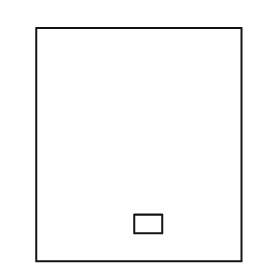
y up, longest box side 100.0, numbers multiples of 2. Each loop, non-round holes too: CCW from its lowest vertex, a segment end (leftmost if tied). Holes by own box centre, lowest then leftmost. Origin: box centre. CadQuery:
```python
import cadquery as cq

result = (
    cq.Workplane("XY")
    .moveTo(-44.0, -50.0)
    .lineTo(44.0, -50.0)
    .lineTo(44.0, 50.0)
    .lineTo(-44.0, 50.0)
    .close()
    .moveTo(-2.0, -38.0)
    .lineTo(10.0, -38.0)
    .lineTo(10.0, -30.0)
    .lineTo(-2.0, -30.0)
    .close()
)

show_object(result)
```